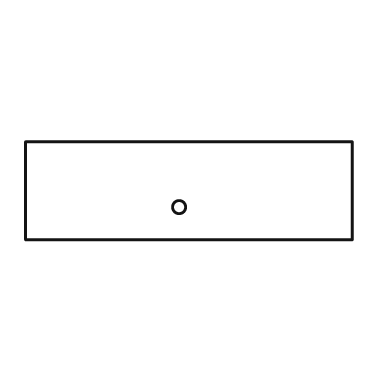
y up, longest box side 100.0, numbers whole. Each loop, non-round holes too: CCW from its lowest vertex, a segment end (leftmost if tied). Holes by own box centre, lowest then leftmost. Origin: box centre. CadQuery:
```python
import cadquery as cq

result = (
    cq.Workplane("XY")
    .moveTo(-50.0, -15.0)
    .lineTo(50.0, -15.0)
    .lineTo(50.0, 15.0)
    .lineTo(-50.0, 15.0)
    .close()
    .moveTo(-3.0, -5.0)
    .circle(2.0)
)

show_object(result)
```